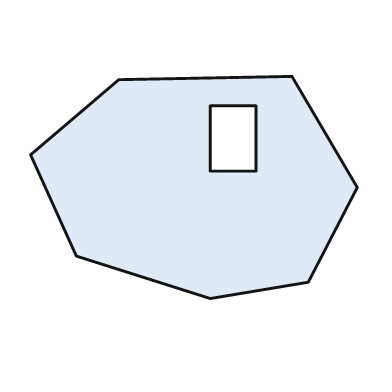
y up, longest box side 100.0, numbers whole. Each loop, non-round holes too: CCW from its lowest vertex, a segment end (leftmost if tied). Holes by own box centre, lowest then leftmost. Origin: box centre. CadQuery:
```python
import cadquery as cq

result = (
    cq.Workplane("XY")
    .moveTo(5.0, -34.0)
    .lineTo(35.0, -29.0)
    .lineTo(50.0, 0.0)
    .lineTo(30.0, 34.0)
    .lineTo(-23.0, 33.0)
    .lineTo(-50.0, 10.0)
    .lineTo(-36.0, -21.0)
    .close()
    .moveTo(5.0, 5.0)
    .lineTo(19.0, 5.0)
    .lineTo(19.0, 25.0)
    .lineTo(5.0, 25.0)
    .close()
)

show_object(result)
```